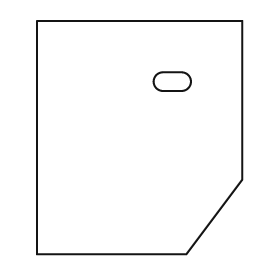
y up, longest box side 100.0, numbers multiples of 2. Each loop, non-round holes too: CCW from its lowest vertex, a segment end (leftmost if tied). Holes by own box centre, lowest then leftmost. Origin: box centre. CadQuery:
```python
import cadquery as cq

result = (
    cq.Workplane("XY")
    .moveTo(-44.0, -50.0)
    .lineTo(20.0, -50.0)
    .lineTo(44.0, -18.0)
    .lineTo(44.0, 50.0)
    .lineTo(-44.0, 50.0)
    .close()
    .moveTo(10.0, 20.0)
    .lineTo(18.0, 20.0)
    .threePointArc((22.0, 24.0), (18.0, 28.0))
    .lineTo(10.0, 28.0)
    .threePointArc((6.0, 24.0), (10.0, 20.0))
    .close()
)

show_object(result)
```